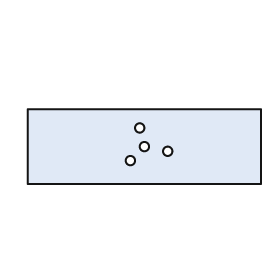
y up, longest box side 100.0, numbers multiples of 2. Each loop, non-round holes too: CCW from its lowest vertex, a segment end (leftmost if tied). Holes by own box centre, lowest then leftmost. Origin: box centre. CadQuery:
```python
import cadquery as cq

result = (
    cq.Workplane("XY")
    .moveTo(-50.0, -16.0)
    .lineTo(50.0, -16.0)
    .lineTo(50.0, 16.0)
    .lineTo(-50.0, 16.0)
    .close()
    .moveTo(-6.0, -6.0)
    .circle(2.0)
    .moveTo(10.0, -2.0)
    .circle(2.0)
    .moveTo(0.0, 0.0)
    .circle(2.0)
    .moveTo(-2.0, 8.0)
    .circle(2.0)
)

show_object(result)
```